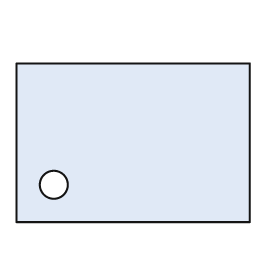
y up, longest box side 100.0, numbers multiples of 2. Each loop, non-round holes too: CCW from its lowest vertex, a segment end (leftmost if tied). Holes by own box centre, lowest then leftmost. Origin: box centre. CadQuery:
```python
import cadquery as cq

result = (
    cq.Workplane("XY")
    .moveTo(-50.0, -34.0)
    .lineTo(50.0, -34.0)
    .lineTo(50.0, 34.0)
    .lineTo(-50.0, 34.0)
    .close()
    .moveTo(-34.0, -18.0)
    .circle(6.0)
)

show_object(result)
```